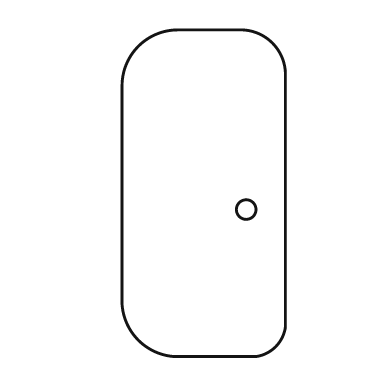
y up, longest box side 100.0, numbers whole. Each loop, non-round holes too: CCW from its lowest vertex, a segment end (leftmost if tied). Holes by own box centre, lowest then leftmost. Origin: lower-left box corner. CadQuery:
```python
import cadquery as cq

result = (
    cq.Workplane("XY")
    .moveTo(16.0, 0.0)
    .lineTo(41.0, 0.0)
    .threePointArc((47.0, 3.0), (50.0, 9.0))
    .lineTo(50.0, 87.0)
    .threePointArc((46.0, 96.0), (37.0, 100.0))
    .lineTo(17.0, 100.0)
    .threePointArc((5.0, 95.0), (0.0, 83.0))
    .lineTo(0.0, 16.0)
    .threePointArc((5.0, 5.0), (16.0, 0.0))
    .close()
    .moveTo(38.0, 45.0)
    .circle(3.0)
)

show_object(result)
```